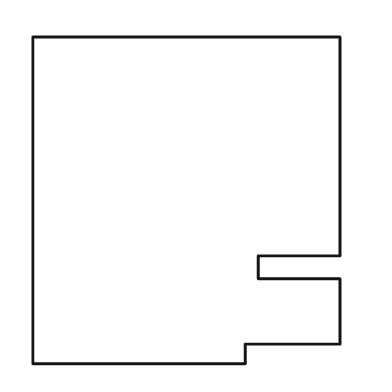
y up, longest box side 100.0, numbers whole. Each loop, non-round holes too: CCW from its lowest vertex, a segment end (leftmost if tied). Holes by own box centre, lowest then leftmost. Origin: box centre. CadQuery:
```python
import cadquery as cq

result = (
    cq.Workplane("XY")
    .moveTo(-47.0, -50.0)
    .lineTo(18.0, -50.0)
    .lineTo(18.0, -44.0)
    .lineTo(47.0, -44.0)
    .lineTo(47.0, -24.0)
    .lineTo(22.0, -24.0)
    .lineTo(22.0, -17.0)
    .lineTo(47.0, -17.0)
    .lineTo(47.0, 50.0)
    .lineTo(-47.0, 50.0)
    .close()
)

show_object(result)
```